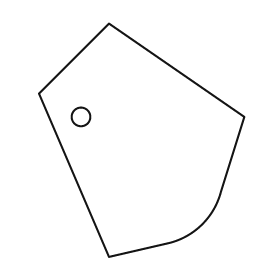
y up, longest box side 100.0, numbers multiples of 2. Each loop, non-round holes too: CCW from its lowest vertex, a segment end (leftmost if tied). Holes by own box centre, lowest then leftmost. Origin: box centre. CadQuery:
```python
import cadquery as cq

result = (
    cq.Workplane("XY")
    .moveTo(-14.0, -50.0)
    .lineTo(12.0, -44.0)
    .threePointArc((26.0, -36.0), (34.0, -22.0))
    .lineTo(44.0, 10.0)
    .lineTo(-14.0, 50.0)
    .lineTo(-44.0, 20.0)
    .close()
    .moveTo(-26.0, 10.0)
    .circle(4.0)
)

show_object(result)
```